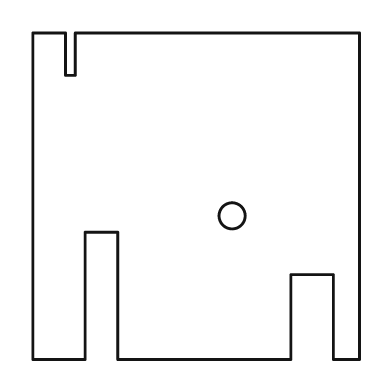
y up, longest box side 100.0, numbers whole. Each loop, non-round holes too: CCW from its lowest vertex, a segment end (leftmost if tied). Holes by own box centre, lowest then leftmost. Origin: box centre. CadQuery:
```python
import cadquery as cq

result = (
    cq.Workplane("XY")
    .moveTo(-50.0, -50.0)
    .lineTo(-34.0, -50.0)
    .lineTo(-34.0, -11.0)
    .lineTo(-24.0, -11.0)
    .lineTo(-24.0, -50.0)
    .lineTo(29.0, -50.0)
    .lineTo(29.0, -24.0)
    .lineTo(42.0, -24.0)
    .lineTo(42.0, -50.0)
    .lineTo(50.0, -50.0)
    .lineTo(50.0, 50.0)
    .lineTo(-37.0, 50.0)
    .lineTo(-37.0, 37.0)
    .lineTo(-40.0, 37.0)
    .lineTo(-40.0, 50.0)
    .lineTo(-50.0, 50.0)
    .close()
    .moveTo(11.0, -6.0)
    .circle(4.0)
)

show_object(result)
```